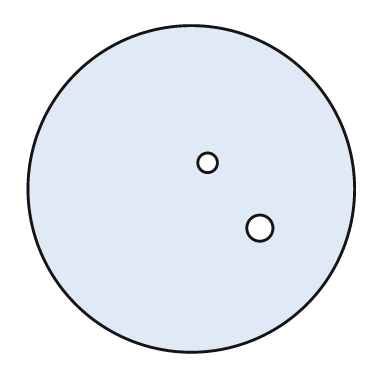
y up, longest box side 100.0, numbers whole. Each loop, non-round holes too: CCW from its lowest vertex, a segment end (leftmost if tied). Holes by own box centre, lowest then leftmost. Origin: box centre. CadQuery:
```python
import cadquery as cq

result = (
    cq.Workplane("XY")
    .moveTo(0.0, 0.0)
    .circle(50.0)
    .moveTo(21.0, -12.0)
    .circle(4.0)
    .moveTo(5.0, 8.0)
    .circle(3.0)
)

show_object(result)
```